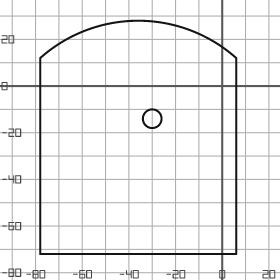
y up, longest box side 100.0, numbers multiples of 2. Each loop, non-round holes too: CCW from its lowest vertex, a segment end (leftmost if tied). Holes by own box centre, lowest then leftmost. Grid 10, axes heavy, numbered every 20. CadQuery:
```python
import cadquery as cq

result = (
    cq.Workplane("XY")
    .moveTo(-78.0, -72.0)
    .lineTo(6.0, -72.0)
    .lineTo(6.0, 12.0)
    .threePointArc((-36.0, 28.0), (-78.0, 12.0))
    .close()
    .moveTo(-30.0, -14.0)
    .circle(4.0)
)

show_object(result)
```